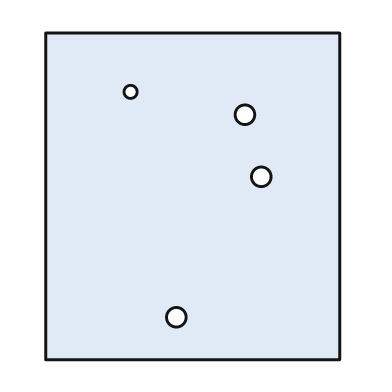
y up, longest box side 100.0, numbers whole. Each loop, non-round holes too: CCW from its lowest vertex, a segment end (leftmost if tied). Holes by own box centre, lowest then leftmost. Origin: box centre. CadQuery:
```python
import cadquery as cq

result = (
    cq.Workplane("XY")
    .moveTo(-45.0, -50.0)
    .lineTo(45.0, -50.0)
    .lineTo(45.0, 50.0)
    .lineTo(-45.0, 50.0)
    .close()
    .moveTo(-5.0, -37.0)
    .circle(3.0)
    .moveTo(21.0, 6.0)
    .circle(3.0)
    .moveTo(16.0, 25.0)
    .circle(3.0)
    .moveTo(-19.0, 32.0)
    .circle(2.0)
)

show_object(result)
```